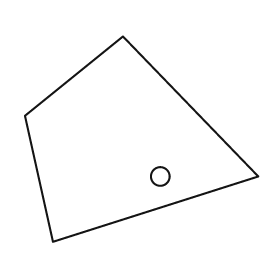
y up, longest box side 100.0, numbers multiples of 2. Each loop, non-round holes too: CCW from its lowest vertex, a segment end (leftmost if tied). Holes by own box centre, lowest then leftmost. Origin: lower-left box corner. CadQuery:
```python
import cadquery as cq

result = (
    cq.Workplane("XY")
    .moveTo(12.0, 0.0)
    .lineTo(100.0, 28.0)
    .lineTo(42.0, 88.0)
    .lineTo(0.0, 54.0)
    .close()
    .moveTo(58.0, 28.0)
    .circle(4.0)
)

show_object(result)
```